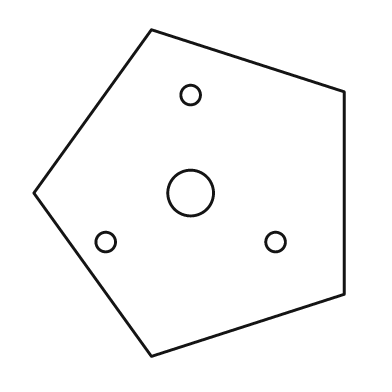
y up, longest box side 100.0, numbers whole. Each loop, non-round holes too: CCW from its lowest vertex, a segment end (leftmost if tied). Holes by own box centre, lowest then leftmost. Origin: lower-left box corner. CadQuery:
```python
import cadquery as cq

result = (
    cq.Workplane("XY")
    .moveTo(36.0, 0.0)
    .lineTo(95.0, 19.0)
    .lineTo(95.0, 81.0)
    .lineTo(36.0, 100.0)
    .lineTo(0.0, 50.0)
    .close()
    .moveTo(22.0, 35.0)
    .circle(3.0)
    .moveTo(74.0, 35.0)
    .circle(3.0)
    .moveTo(48.0, 50.0)
    .circle(7.0)
    .moveTo(48.0, 80.0)
    .circle(3.0)
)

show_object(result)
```